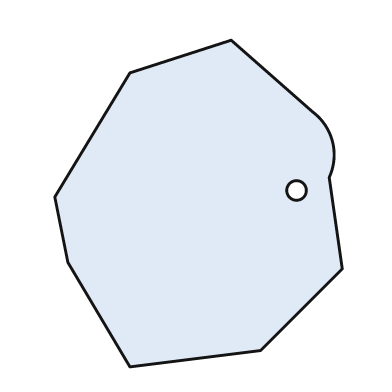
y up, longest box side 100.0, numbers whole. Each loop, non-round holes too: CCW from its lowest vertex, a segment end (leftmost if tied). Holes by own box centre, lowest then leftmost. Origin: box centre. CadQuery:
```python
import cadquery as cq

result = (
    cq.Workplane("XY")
    .moveTo(-21.0, -50.0)
    .lineTo(19.0, -45.0)
    .lineTo(44.0, -20.0)
    .lineTo(40.0, 8.0)
    .threePointArc((41.0, 19.0), (35.0, 28.0))
    .lineTo(10.0, 50.0)
    .lineTo(-21.0, 40.0)
    .lineTo(-44.0, 2.0)
    .lineTo(-40.0, -18.0)
    .close()
    .moveTo(30.0, 4.0)
    .circle(3.0)
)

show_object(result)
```